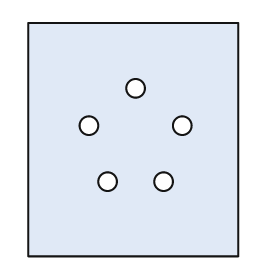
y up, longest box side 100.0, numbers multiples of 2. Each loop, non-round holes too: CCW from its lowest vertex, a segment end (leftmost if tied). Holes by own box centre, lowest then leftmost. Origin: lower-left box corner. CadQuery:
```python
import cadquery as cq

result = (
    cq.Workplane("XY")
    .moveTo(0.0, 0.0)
    .lineTo(90.0, 0.0)
    .lineTo(90.0, 100.0)
    .lineTo(0.0, 100.0)
    .close()
    .moveTo(34.0, 32.0)
    .circle(4.0)
    .moveTo(58.0, 32.0)
    .circle(4.0)
    .moveTo(26.0, 56.0)
    .circle(4.0)
    .moveTo(66.0, 56.0)
    .circle(4.0)
    .moveTo(46.0, 72.0)
    .circle(4.0)
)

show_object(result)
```